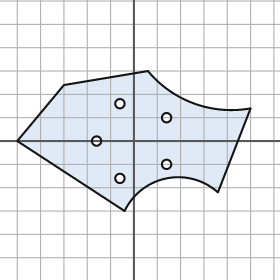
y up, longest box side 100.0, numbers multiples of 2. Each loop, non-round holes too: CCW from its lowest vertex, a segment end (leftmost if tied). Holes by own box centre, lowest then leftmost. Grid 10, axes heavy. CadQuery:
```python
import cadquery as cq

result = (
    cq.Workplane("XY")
    .moveTo(-4.0, -30.0)
    .threePointArc((14.0, -16.0), (36.0, -22.0))
    .lineTo(50.0, 14.0)
    .threePointArc((26.0, 16.0), (6.0, 30.0))
    .lineTo(-30.0, 24.0)
    .lineTo(-50.0, 0.0)
    .close()
    .moveTo(-6.0, -16.0)
    .circle(2.0)
    .moveTo(14.0, -10.0)
    .circle(2.0)
    .moveTo(-16.0, 0.0)
    .circle(2.0)
    .moveTo(14.0, 10.0)
    .circle(2.0)
    .moveTo(-6.0, 16.0)
    .circle(2.0)
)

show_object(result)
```